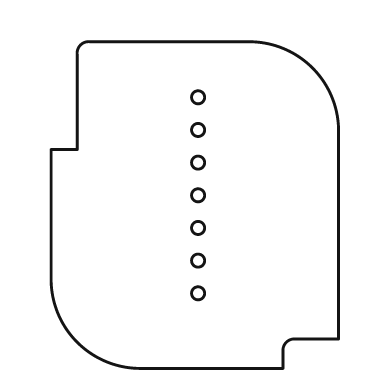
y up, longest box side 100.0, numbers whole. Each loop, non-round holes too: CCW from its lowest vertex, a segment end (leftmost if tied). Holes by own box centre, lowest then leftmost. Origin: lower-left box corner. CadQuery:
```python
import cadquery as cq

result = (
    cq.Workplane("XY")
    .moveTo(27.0, 0.0)
    .lineTo(71.0, 0.0)
    .lineTo(71.0, 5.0)
    .threePointArc((72.0, 8.0), (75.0, 9.0))
    .lineTo(88.0, 9.0)
    .lineTo(88.0, 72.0)
    .threePointArc((80.0, 92.0), (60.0, 100.0))
    .lineTo(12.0, 100.0)
    .threePointArc((9.0, 99.0), (8.0, 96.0))
    .lineTo(8.0, 67.0)
    .lineTo(0.0, 67.0)
    .lineTo(0.0, 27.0)
    .threePointArc((8.0, 8.0), (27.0, 0.0))
    .close()
    .moveTo(45.0, 23.0)
    .circle(2.0)
    .moveTo(45.0, 33.0)
    .circle(2.0)
    .moveTo(45.0, 43.0)
    .circle(2.0)
    .moveTo(45.0, 53.0)
    .circle(2.0)
    .moveTo(45.0, 63.0)
    .circle(2.0)
    .moveTo(45.0, 73.0)
    .circle(2.0)
    .moveTo(45.0, 83.0)
    .circle(2.0)
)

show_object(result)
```